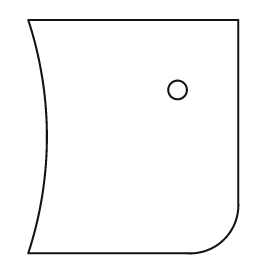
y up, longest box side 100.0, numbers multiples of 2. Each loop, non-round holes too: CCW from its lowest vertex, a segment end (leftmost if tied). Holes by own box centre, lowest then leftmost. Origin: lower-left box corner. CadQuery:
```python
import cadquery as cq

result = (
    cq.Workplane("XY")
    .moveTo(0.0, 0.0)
    .lineTo(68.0, 0.0)
    .threePointArc((84.0, 6.0), (90.0, 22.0))
    .lineTo(90.0, 100.0)
    .lineTo(0.0, 100.0)
    .threePointArc((8.0, 50.0), (0.0, 0.0))
    .close()
    .moveTo(64.0, 70.0)
    .circle(4.0)
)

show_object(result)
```